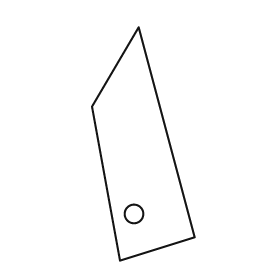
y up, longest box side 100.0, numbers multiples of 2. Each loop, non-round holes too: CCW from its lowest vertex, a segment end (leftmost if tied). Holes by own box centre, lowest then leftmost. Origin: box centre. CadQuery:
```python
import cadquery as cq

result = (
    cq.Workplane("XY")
    .moveTo(-10.0, -50.0)
    .lineTo(22.0, -40.0)
    .lineTo(-2.0, 50.0)
    .lineTo(-22.0, 16.0)
    .close()
    .moveTo(-4.0, -30.0)
    .circle(4.0)
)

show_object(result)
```